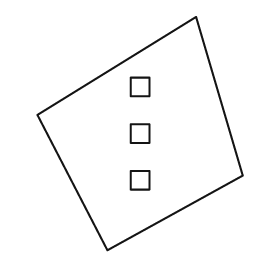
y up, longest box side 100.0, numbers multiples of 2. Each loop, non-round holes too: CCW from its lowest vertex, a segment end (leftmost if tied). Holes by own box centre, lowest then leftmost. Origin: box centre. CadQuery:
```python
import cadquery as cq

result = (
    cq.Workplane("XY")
    .moveTo(-14.0, -50.0)
    .lineTo(44.0, -18.0)
    .lineTo(24.0, 50.0)
    .lineTo(-44.0, 8.0)
    .close()
    .moveTo(-4.0, -24.0)
    .lineTo(4.0, -24.0)
    .lineTo(4.0, -16.0)
    .lineTo(-4.0, -16.0)
    .close()
    .moveTo(-4.0, -4.0)
    .lineTo(4.0, -4.0)
    .lineTo(4.0, 4.0)
    .lineTo(-4.0, 4.0)
    .close()
    .moveTo(-4.0, 16.0)
    .lineTo(4.0, 16.0)
    .lineTo(4.0, 24.0)
    .lineTo(-4.0, 24.0)
    .close()
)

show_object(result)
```